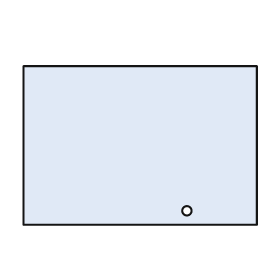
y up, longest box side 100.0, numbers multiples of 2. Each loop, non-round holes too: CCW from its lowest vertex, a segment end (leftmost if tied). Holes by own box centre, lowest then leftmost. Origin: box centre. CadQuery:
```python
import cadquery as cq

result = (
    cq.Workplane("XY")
    .moveTo(-50.0, -34.0)
    .lineTo(50.0, -34.0)
    .lineTo(50.0, 34.0)
    .lineTo(-50.0, 34.0)
    .close()
    .moveTo(20.0, -28.0)
    .circle(2.0)
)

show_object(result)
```